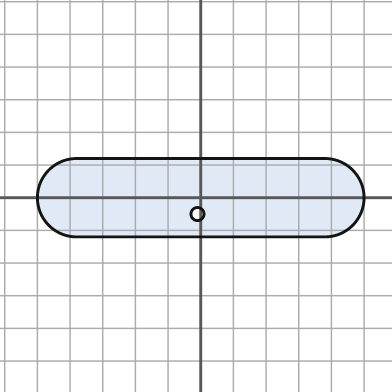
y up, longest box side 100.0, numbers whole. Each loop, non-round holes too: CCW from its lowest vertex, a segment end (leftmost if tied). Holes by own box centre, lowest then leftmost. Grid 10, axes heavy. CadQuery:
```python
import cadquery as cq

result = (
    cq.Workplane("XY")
    .moveTo(-38.0, -12.0)
    .lineTo(38.0, -12.0)
    .threePointArc((50.0, 0.0), (38.0, 12.0))
    .lineTo(-38.0, 12.0)
    .threePointArc((-50.0, 0.0), (-38.0, -12.0))
    .close()
    .moveTo(-1.0, -5.0)
    .circle(2.0)
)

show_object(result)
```